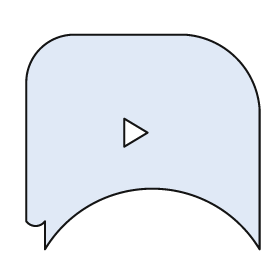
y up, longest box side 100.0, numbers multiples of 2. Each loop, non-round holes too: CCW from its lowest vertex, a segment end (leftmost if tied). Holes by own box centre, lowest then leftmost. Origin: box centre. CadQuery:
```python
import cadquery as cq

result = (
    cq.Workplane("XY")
    .moveTo(-42.0, -46.0)
    .threePointArc((4.0, -20.0), (50.0, -46.0))
    .lineTo(50.0, 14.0)
    .threePointArc((40.0, 36.0), (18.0, 46.0))
    .lineTo(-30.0, 46.0)
    .threePointArc((-44.0, 40.0), (-50.0, 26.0))
    .lineTo(-50.0, -34.0)
    .threePointArc((-46.0, -36.0), (-42.0, -34.0))
    .close()
    .moveTo(-8.0, -2.0)
    .lineTo(2.0, 4.0)
    .lineTo(-8.0, 10.0)
    .close()
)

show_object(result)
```